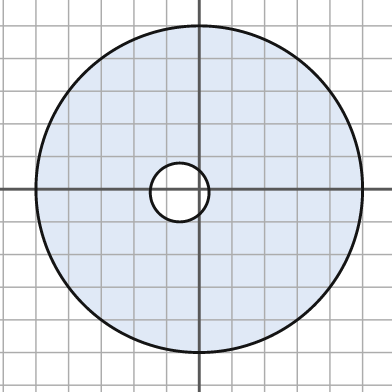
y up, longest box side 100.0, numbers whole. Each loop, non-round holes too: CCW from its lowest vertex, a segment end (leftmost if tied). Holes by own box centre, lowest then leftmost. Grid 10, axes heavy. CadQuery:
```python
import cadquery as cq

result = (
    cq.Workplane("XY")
    .moveTo(0.0, 0.0)
    .circle(50.0)
    .moveTo(-6.0, -1.0)
    .circle(9.0)
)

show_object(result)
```